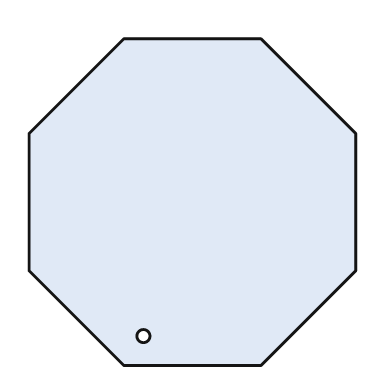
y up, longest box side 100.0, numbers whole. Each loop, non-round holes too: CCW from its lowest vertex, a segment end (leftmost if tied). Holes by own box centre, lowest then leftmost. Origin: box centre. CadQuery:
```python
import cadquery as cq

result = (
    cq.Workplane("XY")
    .moveTo(-21.0, -50.0)
    .lineTo(21.0, -50.0)
    .lineTo(50.0, -21.0)
    .lineTo(50.0, 21.0)
    .lineTo(21.0, 50.0)
    .lineTo(-21.0, 50.0)
    .lineTo(-50.0, 21.0)
    .lineTo(-50.0, -21.0)
    .close()
    .moveTo(-15.0, -41.0)
    .circle(2.0)
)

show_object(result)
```